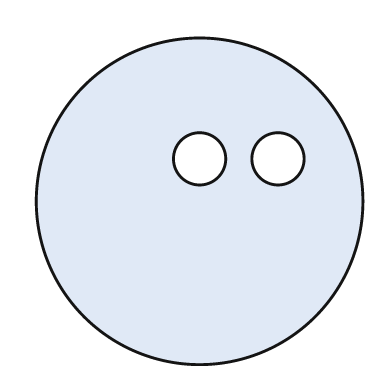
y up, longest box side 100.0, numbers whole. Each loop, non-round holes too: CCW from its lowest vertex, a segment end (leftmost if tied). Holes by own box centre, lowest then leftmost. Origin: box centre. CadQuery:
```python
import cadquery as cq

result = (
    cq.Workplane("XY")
    .moveTo(0.0, 0.0)
    .circle(50.0)
    .moveTo(0.0, 13.0)
    .circle(8.0)
    .moveTo(24.0, 13.0)
    .circle(8.0)
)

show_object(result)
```